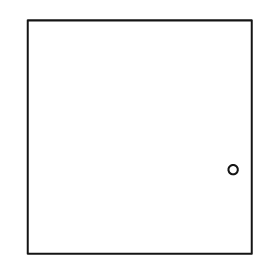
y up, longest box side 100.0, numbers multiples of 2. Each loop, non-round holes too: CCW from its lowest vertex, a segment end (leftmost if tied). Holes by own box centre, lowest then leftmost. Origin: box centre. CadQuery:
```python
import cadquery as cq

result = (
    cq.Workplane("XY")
    .moveTo(-48.0, -50.0)
    .lineTo(48.0, -50.0)
    .lineTo(48.0, 50.0)
    .lineTo(-48.0, 50.0)
    .close()
    .moveTo(40.0, -14.0)
    .circle(2.0)
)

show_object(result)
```